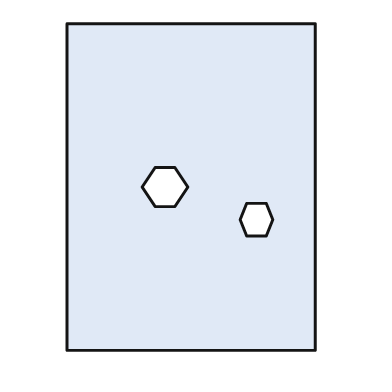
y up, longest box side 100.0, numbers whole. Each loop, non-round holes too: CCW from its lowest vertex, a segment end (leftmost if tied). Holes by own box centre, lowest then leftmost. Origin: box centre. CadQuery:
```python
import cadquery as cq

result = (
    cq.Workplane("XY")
    .moveTo(-38.0, -50.0)
    .lineTo(38.0, -50.0)
    .lineTo(38.0, 50.0)
    .lineTo(-38.0, 50.0)
    .close()
    .moveTo(17.0, -15.0)
    .lineTo(23.0, -15.0)
    .lineTo(25.0, -10.0)
    .lineTo(23.0, -5.0)
    .lineTo(17.0, -5.0)
    .lineTo(15.0, -10.0)
    .close()
    .moveTo(-11.0, -6.0)
    .lineTo(-5.0, -6.0)
    .lineTo(-1.0, 0.0)
    .lineTo(-5.0, 6.0)
    .lineTo(-11.0, 6.0)
    .lineTo(-15.0, 0.0)
    .close()
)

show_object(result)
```